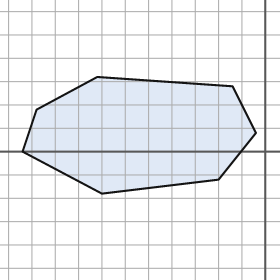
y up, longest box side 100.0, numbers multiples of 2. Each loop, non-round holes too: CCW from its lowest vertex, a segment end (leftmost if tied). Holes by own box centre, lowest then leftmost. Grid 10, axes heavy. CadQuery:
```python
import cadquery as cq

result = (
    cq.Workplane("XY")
    .moveTo(-70.0, -18.0)
    .lineTo(-20.0, -12.0)
    .lineTo(-4.0, 8.0)
    .lineTo(-14.0, 28.0)
    .lineTo(-72.0, 32.0)
    .lineTo(-98.0, 18.0)
    .lineTo(-104.0, 0.0)
    .close()
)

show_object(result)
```